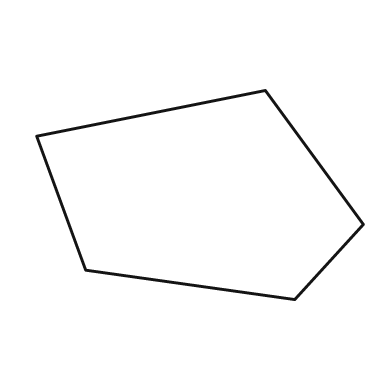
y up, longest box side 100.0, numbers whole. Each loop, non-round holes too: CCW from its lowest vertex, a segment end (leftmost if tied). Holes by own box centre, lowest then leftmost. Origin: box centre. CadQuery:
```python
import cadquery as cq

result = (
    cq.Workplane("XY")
    .moveTo(29.0, -32.0)
    .lineTo(50.0, -9.0)
    .lineTo(20.0, 32.0)
    .lineTo(-50.0, 18.0)
    .lineTo(-35.0, -23.0)
    .close()
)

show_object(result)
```